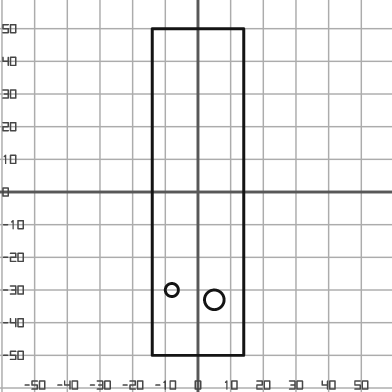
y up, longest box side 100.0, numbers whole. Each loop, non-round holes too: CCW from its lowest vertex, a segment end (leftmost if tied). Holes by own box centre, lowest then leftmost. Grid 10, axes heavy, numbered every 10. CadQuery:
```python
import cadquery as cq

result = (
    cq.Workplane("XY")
    .moveTo(-14.0, -50.0)
    .lineTo(14.0, -50.0)
    .lineTo(14.0, 50.0)
    .lineTo(-14.0, 50.0)
    .close()
    .moveTo(5.0, -33.0)
    .circle(3.0)
    .moveTo(-8.0, -30.0)
    .circle(2.0)
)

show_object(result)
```